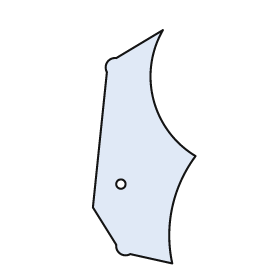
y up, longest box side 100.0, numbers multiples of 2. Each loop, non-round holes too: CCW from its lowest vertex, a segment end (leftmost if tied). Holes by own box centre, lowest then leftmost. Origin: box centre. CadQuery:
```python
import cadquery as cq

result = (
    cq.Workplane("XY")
    .moveTo(12.0, -50.0)
    .threePointArc((12.0, -26.0), (22.0, -4.0))
    .threePointArc((4.0, 20.0), (8.0, 50.0))
    .lineTo(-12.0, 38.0)
    .threePointArc((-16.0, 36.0), (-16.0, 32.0))
    .lineTo(-22.0, -26.0)
    .lineTo(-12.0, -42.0)
    .threePointArc((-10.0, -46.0), (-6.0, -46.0))
    .close()
    .moveTo(-10.0, -16.0)
    .circle(2.0)
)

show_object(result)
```